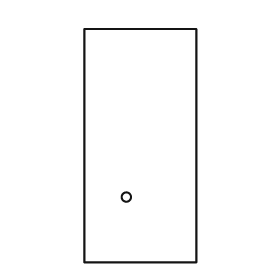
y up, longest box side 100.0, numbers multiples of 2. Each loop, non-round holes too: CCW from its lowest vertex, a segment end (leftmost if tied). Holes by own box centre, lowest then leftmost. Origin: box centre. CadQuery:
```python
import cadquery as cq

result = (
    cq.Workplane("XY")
    .moveTo(-24.0, -50.0)
    .lineTo(24.0, -50.0)
    .lineTo(24.0, 50.0)
    .lineTo(-24.0, 50.0)
    .close()
    .moveTo(-6.0, -22.0)
    .circle(2.0)
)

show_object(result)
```